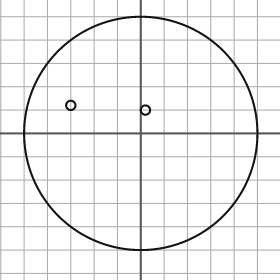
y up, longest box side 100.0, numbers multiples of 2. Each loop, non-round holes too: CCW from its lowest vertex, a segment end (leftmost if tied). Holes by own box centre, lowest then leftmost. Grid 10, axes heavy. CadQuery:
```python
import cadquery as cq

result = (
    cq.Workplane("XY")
    .moveTo(0.0, 0.0)
    .circle(50.0)
    .moveTo(2.0, 10.0)
    .circle(2.0)
    .moveTo(-30.0, 12.0)
    .circle(2.0)
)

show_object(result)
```